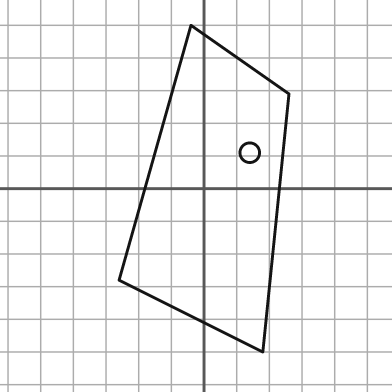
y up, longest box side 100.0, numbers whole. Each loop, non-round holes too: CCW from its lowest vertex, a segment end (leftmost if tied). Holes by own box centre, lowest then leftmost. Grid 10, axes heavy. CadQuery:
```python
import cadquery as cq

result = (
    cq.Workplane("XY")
    .moveTo(18.0, -50.0)
    .lineTo(26.0, 29.0)
    .lineTo(-4.0, 50.0)
    .lineTo(-26.0, -28.0)
    .close()
    .moveTo(14.0, 11.0)
    .circle(3.0)
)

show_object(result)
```